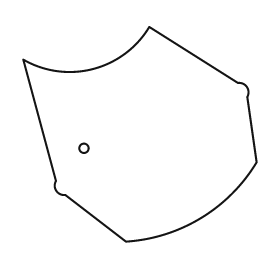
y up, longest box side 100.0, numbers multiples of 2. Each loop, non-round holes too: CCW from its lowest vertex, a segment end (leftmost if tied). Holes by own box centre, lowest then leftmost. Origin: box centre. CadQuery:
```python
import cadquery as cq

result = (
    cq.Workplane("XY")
    .moveTo(-6.0, -46.0)
    .threePointArc((26.0, -36.0), (50.0, -12.0))
    .lineTo(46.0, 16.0)
    .threePointArc((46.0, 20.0), (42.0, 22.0))
    .lineTo(4.0, 46.0)
    .threePointArc((-20.0, 28.0), (-50.0, 32.0))
    .lineTo(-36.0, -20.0)
    .threePointArc((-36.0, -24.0), (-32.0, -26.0))
    .close()
    .moveTo(-24.0, -6.0)
    .circle(2.0)
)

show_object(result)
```